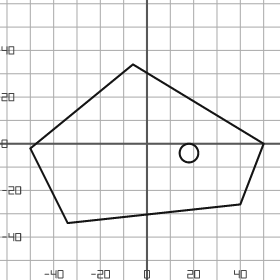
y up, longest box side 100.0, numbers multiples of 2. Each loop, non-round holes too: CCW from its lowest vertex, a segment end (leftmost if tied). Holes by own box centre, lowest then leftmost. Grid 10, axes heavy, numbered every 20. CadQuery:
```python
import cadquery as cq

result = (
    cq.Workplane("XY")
    .moveTo(-34.0, -34.0)
    .lineTo(40.0, -26.0)
    .lineTo(50.0, 0.0)
    .lineTo(-6.0, 34.0)
    .lineTo(-50.0, -2.0)
    .close()
    .moveTo(18.0, -4.0)
    .circle(4.0)
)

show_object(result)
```